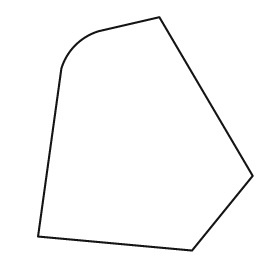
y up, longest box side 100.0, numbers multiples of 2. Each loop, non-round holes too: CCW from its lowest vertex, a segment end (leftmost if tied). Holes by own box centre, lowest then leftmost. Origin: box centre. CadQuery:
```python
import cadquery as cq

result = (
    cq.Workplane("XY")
    .moveTo(20.0, -50.0)
    .lineTo(46.0, -18.0)
    .lineTo(6.0, 50.0)
    .lineTo(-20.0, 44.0)
    .threePointArc((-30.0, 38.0), (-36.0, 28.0))
    .lineTo(-46.0, -44.0)
    .close()
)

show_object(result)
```